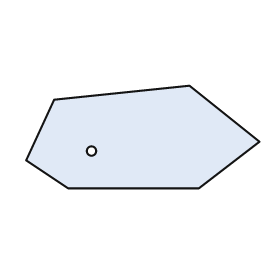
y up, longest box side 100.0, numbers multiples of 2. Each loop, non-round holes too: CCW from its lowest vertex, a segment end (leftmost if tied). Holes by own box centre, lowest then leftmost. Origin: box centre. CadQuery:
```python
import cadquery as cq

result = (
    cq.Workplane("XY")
    .moveTo(-32.0, -22.0)
    .lineTo(24.0, -22.0)
    .lineTo(50.0, -2.0)
    .lineTo(20.0, 22.0)
    .lineTo(-38.0, 16.0)
    .lineTo(-50.0, -10.0)
    .close()
    .moveTo(-22.0, -6.0)
    .circle(2.0)
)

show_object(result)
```